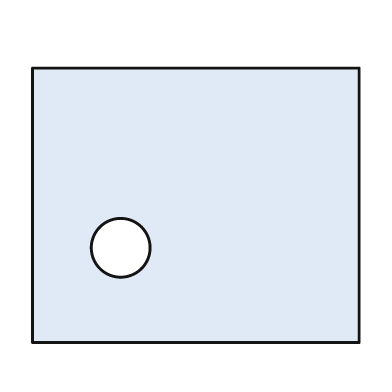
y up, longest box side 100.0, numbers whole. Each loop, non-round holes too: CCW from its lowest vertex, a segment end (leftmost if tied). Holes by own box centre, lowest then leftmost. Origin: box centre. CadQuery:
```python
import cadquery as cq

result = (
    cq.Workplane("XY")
    .moveTo(-50.0, -42.0)
    .lineTo(50.0, -42.0)
    .lineTo(50.0, 42.0)
    .lineTo(-50.0, 42.0)
    .close()
    .moveTo(-23.0, -13.0)
    .circle(9.0)
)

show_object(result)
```